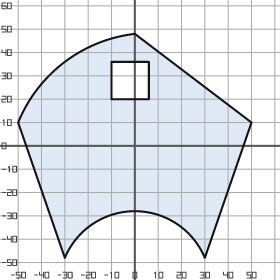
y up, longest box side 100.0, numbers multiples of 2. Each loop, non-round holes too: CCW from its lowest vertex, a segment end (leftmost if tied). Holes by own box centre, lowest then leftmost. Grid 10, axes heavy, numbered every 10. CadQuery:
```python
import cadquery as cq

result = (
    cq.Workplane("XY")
    .moveTo(-30.0, -48.0)
    .threePointArc((0.0, -28.0), (30.0, -48.0))
    .lineTo(50.0, 10.0)
    .lineTo(0.0, 48.0)
    .threePointArc((-30.0, 36.0), (-50.0, 10.0))
    .close()
    .moveTo(-10.0, 20.0)
    .lineTo(6.0, 20.0)
    .lineTo(6.0, 36.0)
    .lineTo(-10.0, 36.0)
    .close()
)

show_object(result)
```